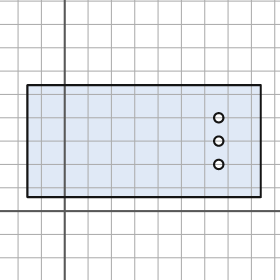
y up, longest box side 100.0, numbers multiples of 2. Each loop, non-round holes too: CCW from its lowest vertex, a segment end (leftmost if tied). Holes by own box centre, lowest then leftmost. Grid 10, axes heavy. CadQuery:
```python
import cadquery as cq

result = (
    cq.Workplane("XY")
    .moveTo(-16.0, 6.0)
    .lineTo(84.0, 6.0)
    .lineTo(84.0, 54.0)
    .lineTo(-16.0, 54.0)
    .close()
    .moveTo(66.0, 20.0)
    .circle(2.0)
    .moveTo(66.0, 30.0)
    .circle(2.0)
    .moveTo(66.0, 40.0)
    .circle(2.0)
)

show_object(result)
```